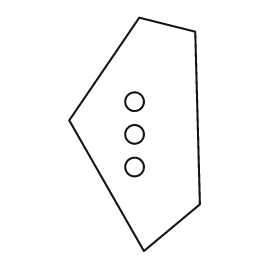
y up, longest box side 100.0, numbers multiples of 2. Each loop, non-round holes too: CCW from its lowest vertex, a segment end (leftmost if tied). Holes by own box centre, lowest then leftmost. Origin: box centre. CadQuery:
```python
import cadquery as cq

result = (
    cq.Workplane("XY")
    .moveTo(4.0, -50.0)
    .lineTo(28.0, -30.0)
    .lineTo(26.0, 44.0)
    .lineTo(2.0, 50.0)
    .lineTo(-28.0, 6.0)
    .close()
    .moveTo(0.0, -14.0)
    .circle(4.0)
    .moveTo(0.0, 0.0)
    .circle(4.0)
    .moveTo(0.0, 14.0)
    .circle(4.0)
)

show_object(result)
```